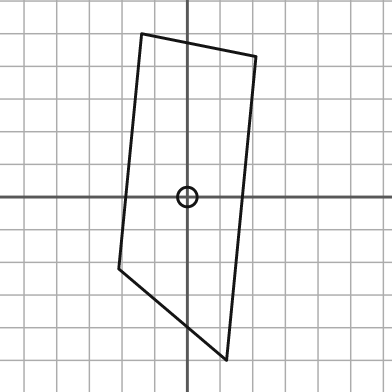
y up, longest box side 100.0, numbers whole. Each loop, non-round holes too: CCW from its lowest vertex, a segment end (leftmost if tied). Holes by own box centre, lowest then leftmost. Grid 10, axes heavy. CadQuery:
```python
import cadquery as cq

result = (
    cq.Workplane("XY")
    .moveTo(12.0, -50.0)
    .lineTo(21.0, 43.0)
    .lineTo(-14.0, 50.0)
    .lineTo(-21.0, -22.0)
    .close()
    .moveTo(0.0, 0.0)
    .circle(3.0)
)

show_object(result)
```